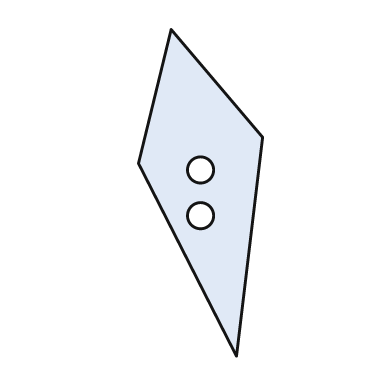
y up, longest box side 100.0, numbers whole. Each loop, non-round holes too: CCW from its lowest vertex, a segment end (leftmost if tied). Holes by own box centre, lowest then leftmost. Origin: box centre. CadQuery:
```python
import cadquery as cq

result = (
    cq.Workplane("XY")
    .moveTo(11.0, -50.0)
    .lineTo(19.0, 17.0)
    .lineTo(-9.0, 50.0)
    .lineTo(-19.0, 9.0)
    .close()
    .moveTo(0.0, -7.0)
    .circle(4.0)
    .moveTo(0.0, 7.0)
    .circle(4.0)
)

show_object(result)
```